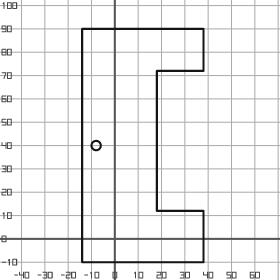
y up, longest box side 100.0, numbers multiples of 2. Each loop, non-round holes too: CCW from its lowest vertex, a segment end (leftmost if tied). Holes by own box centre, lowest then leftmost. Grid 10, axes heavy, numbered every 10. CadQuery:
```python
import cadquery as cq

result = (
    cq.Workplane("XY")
    .moveTo(-14.0, -10.0)
    .lineTo(38.0, -10.0)
    .lineTo(38.0, 12.0)
    .lineTo(18.0, 12.0)
    .lineTo(18.0, 72.0)
    .lineTo(38.0, 72.0)
    .lineTo(38.0, 90.0)
    .lineTo(-14.0, 90.0)
    .close()
    .moveTo(-8.0, 40.0)
    .circle(2.0)
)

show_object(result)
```